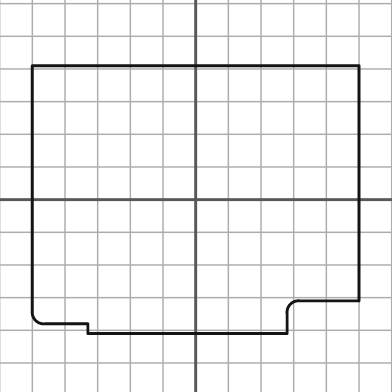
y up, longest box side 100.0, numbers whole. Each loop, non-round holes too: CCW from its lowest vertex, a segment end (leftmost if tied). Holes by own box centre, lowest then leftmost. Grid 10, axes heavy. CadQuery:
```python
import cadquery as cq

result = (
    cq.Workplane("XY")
    .moveTo(-33.0, -41.0)
    .lineTo(28.0, -41.0)
    .lineTo(28.0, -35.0)
    .threePointArc((29.0, -32.0), (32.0, -31.0))
    .lineTo(50.0, -31.0)
    .lineTo(50.0, 41.0)
    .lineTo(-50.0, 41.0)
    .lineTo(-50.0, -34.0)
    .threePointArc((-49.0, -37.0), (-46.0, -38.0))
    .lineTo(-33.0, -38.0)
    .close()
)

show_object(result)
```